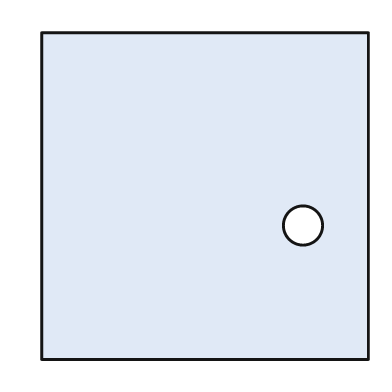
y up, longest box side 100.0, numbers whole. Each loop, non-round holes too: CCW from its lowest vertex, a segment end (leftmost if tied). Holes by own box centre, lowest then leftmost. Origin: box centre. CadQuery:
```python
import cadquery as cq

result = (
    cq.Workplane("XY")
    .moveTo(-50.0, -50.0)
    .lineTo(50.0, -50.0)
    .lineTo(50.0, 50.0)
    .lineTo(-50.0, 50.0)
    .close()
    .moveTo(30.0, -9.0)
    .circle(6.0)
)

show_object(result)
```